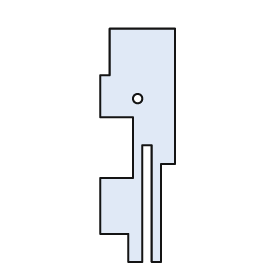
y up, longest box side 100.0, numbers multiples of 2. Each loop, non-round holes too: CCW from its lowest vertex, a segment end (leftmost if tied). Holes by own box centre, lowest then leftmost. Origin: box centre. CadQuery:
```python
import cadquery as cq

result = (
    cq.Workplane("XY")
    .moveTo(-4.0, -50.0)
    .lineTo(2.0, -50.0)
    .lineTo(2.0, 0.0)
    .lineTo(6.0, 0.0)
    .lineTo(6.0, -50.0)
    .lineTo(10.0, -50.0)
    .lineTo(10.0, -8.0)
    .lineTo(16.0, -8.0)
    .lineTo(16.0, 50.0)
    .lineTo(-12.0, 50.0)
    .lineTo(-12.0, 30.0)
    .lineTo(-16.0, 30.0)
    .lineTo(-16.0, 12.0)
    .lineTo(-2.0, 12.0)
    .lineTo(-2.0, -14.0)
    .lineTo(-16.0, -14.0)
    .lineTo(-16.0, -38.0)
    .lineTo(-4.0, -38.0)
    .close()
    .moveTo(0.0, 20.0)
    .circle(2.0)
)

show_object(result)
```